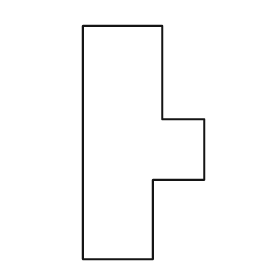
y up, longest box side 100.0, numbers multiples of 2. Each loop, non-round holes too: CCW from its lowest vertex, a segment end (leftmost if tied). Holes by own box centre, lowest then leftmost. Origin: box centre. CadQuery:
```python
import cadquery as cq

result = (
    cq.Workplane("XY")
    .moveTo(-26.0, -50.0)
    .lineTo(4.0, -50.0)
    .lineTo(4.0, -16.0)
    .lineTo(26.0, -16.0)
    .lineTo(26.0, 10.0)
    .lineTo(8.0, 10.0)
    .lineTo(8.0, 50.0)
    .lineTo(-26.0, 50.0)
    .close()
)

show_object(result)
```